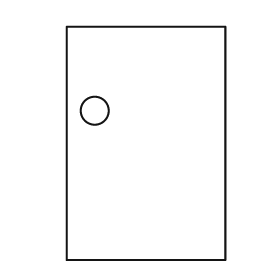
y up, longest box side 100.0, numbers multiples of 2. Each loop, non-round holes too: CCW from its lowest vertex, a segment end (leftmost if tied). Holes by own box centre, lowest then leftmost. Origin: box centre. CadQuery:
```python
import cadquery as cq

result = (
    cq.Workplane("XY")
    .moveTo(-34.0, -50.0)
    .lineTo(34.0, -50.0)
    .lineTo(34.0, 50.0)
    .lineTo(-34.0, 50.0)
    .close()
    .moveTo(-22.0, 14.0)
    .circle(6.0)
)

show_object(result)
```